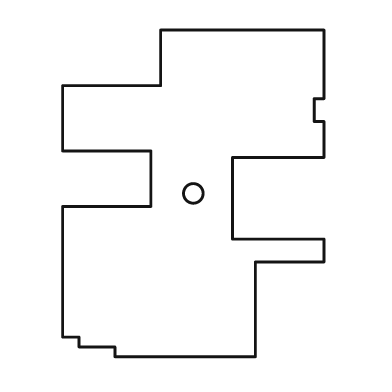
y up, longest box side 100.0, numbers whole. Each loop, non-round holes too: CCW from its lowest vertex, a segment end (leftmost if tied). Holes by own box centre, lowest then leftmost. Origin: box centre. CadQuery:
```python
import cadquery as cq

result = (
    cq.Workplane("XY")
    .moveTo(-24.0, -50.0)
    .lineTo(19.0, -50.0)
    .lineTo(19.0, -21.0)
    .lineTo(40.0, -21.0)
    .lineTo(40.0, -14.0)
    .lineTo(12.0, -14.0)
    .lineTo(12.0, 11.0)
    .lineTo(40.0, 11.0)
    .lineTo(40.0, 22.0)
    .lineTo(37.0, 22.0)
    .lineTo(37.0, 29.0)
    .lineTo(40.0, 29.0)
    .lineTo(40.0, 50.0)
    .lineTo(-10.0, 50.0)
    .lineTo(-10.0, 33.0)
    .lineTo(-40.0, 33.0)
    .lineTo(-40.0, 13.0)
    .lineTo(-13.0, 13.0)
    .lineTo(-13.0, -4.0)
    .lineTo(-40.0, -4.0)
    .lineTo(-40.0, -44.0)
    .lineTo(-35.0, -44.0)
    .lineTo(-35.0, -47.0)
    .lineTo(-24.0, -47.0)
    .close()
    .moveTo(0.0, 0.0)
    .circle(3.0)
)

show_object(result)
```